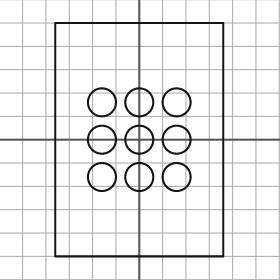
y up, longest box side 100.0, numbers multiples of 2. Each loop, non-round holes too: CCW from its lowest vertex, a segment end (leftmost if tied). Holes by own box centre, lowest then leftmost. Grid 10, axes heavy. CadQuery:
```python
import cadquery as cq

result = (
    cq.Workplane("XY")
    .moveTo(-36.0, -50.0)
    .lineTo(36.0, -50.0)
    .lineTo(36.0, 50.0)
    .lineTo(-36.0, 50.0)
    .close()
    .moveTo(-16.0, -16.0)
    .circle(6.0)
    .moveTo(0.0, -16.0)
    .circle(6.0)
    .moveTo(16.0, -16.0)
    .circle(6.0)
    .moveTo(-16.0, 0.0)
    .circle(6.0)
    .moveTo(0.0, 0.0)
    .circle(6.0)
    .moveTo(16.0, 0.0)
    .circle(6.0)
    .moveTo(-16.0, 16.0)
    .circle(6.0)
    .moveTo(0.0, 16.0)
    .circle(6.0)
    .moveTo(16.0, 16.0)
    .circle(6.0)
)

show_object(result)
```